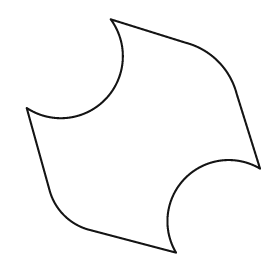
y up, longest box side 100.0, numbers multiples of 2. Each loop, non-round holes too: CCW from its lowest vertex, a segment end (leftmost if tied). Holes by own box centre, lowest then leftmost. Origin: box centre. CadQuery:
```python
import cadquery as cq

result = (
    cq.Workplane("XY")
    .moveTo(14.0, -50.0)
    .threePointArc((18.0, -18.0), (50.0, -14.0))
    .lineTo(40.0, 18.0)
    .threePointArc((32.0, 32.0), (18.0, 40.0))
    .lineTo(-14.0, 50.0)
    .threePointArc((-16.0, 16.0), (-50.0, 12.0))
    .lineTo(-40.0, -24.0)
    .threePointArc((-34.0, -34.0), (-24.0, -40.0))
    .close()
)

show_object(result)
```